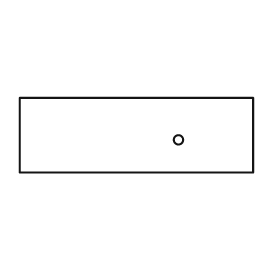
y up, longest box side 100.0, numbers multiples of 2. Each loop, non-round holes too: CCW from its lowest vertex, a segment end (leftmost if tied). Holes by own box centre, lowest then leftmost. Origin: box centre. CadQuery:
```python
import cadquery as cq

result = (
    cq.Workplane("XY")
    .moveTo(-50.0, -16.0)
    .lineTo(50.0, -16.0)
    .lineTo(50.0, 16.0)
    .lineTo(-50.0, 16.0)
    .close()
    .moveTo(18.0, -2.0)
    .circle(2.0)
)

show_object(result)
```